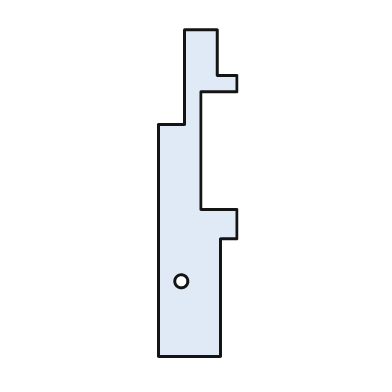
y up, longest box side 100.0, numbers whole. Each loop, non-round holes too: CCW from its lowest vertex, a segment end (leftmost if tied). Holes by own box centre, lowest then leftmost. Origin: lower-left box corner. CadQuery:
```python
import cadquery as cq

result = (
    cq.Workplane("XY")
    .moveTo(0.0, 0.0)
    .lineTo(19.0, 0.0)
    .lineTo(19.0, 36.0)
    .lineTo(24.0, 36.0)
    .lineTo(24.0, 45.0)
    .lineTo(13.0, 45.0)
    .lineTo(13.0, 81.0)
    .lineTo(24.0, 81.0)
    .lineTo(24.0, 86.0)
    .lineTo(18.0, 86.0)
    .lineTo(18.0, 100.0)
    .lineTo(8.0, 100.0)
    .lineTo(8.0, 71.0)
    .lineTo(0.0, 71.0)
    .close()
    .moveTo(7.0, 23.0)
    .circle(2.0)
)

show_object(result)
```